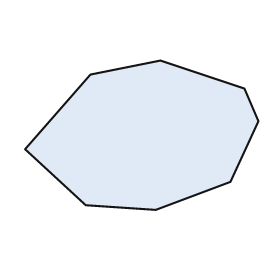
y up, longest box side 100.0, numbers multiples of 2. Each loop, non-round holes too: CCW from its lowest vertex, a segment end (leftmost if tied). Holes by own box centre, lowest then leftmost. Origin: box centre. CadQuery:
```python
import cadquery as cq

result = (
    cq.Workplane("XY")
    .moveTo(6.0, -32.0)
    .lineTo(38.0, -20.0)
    .lineTo(50.0, 6.0)
    .lineTo(44.0, 20.0)
    .lineTo(8.0, 32.0)
    .lineTo(-22.0, 26.0)
    .lineTo(-50.0, -6.0)
    .lineTo(-24.0, -30.0)
    .close()
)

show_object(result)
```